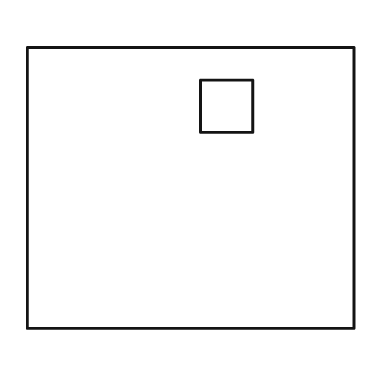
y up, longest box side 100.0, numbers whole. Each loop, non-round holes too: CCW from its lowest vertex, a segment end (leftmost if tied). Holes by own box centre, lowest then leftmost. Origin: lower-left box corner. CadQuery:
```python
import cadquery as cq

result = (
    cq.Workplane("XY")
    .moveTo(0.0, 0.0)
    .lineTo(100.0, 0.0)
    .lineTo(100.0, 86.0)
    .lineTo(0.0, 86.0)
    .close()
    .moveTo(53.0, 60.0)
    .lineTo(69.0, 60.0)
    .lineTo(69.0, 76.0)
    .lineTo(53.0, 76.0)
    .close()
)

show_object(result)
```